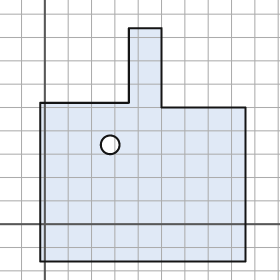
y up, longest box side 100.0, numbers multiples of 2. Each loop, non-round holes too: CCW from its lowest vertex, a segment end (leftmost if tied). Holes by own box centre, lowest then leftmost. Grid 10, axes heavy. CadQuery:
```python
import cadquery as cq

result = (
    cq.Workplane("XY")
    .moveTo(-2.0, -16.0)
    .lineTo(86.0, -16.0)
    .lineTo(86.0, 50.0)
    .lineTo(50.0, 50.0)
    .lineTo(50.0, 84.0)
    .lineTo(36.0, 84.0)
    .lineTo(36.0, 52.0)
    .lineTo(-2.0, 52.0)
    .close()
    .moveTo(28.0, 34.0)
    .circle(4.0)
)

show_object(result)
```